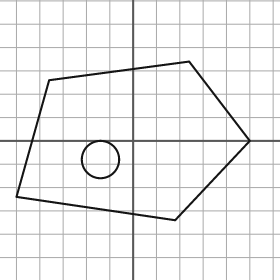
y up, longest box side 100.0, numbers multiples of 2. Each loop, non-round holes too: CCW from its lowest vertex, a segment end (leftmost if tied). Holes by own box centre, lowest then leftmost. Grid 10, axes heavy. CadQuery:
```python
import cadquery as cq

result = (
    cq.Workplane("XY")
    .moveTo(18.0, -34.0)
    .lineTo(50.0, 0.0)
    .lineTo(24.0, 34.0)
    .lineTo(-36.0, 26.0)
    .lineTo(-50.0, -24.0)
    .close()
    .moveTo(-14.0, -8.0)
    .circle(8.0)
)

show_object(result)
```